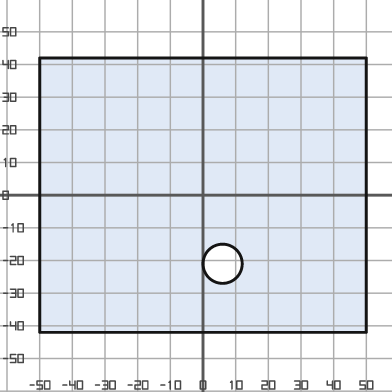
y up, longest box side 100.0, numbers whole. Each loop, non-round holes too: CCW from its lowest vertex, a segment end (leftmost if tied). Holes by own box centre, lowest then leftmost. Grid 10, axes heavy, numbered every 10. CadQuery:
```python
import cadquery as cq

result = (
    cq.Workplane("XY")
    .moveTo(-50.0, -42.0)
    .lineTo(50.0, -42.0)
    .lineTo(50.0, 42.0)
    .lineTo(-50.0, 42.0)
    .close()
    .moveTo(6.0, -21.0)
    .circle(6.0)
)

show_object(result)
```